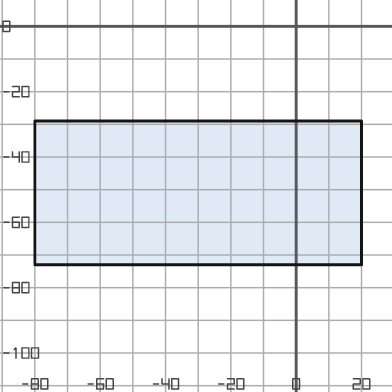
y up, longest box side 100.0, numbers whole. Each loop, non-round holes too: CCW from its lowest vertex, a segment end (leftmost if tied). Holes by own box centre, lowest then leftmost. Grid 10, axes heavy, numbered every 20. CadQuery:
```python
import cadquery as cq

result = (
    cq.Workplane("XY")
    .moveTo(-80.0, -73.0)
    .lineTo(20.0, -73.0)
    .lineTo(20.0, -29.0)
    .lineTo(-80.0, -29.0)
    .close()
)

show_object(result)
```